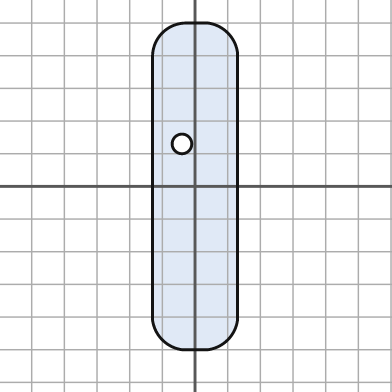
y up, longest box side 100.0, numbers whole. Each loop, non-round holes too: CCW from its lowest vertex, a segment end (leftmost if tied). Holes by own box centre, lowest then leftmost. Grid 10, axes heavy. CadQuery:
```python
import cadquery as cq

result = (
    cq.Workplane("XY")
    .moveTo(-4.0, -50.0)
    .lineTo(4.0, -50.0)
    .threePointArc((10.0, -47.0), (13.0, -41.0))
    .lineTo(13.0, 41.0)
    .threePointArc((10.0, 47.0), (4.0, 50.0))
    .lineTo(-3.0, 50.0)
    .threePointArc((-10.0, 47.0), (-13.0, 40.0))
    .lineTo(-13.0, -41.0)
    .threePointArc((-10.0, -47.0), (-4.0, -50.0))
    .close()
    .moveTo(-4.0, 13.0)
    .circle(3.0)
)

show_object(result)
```